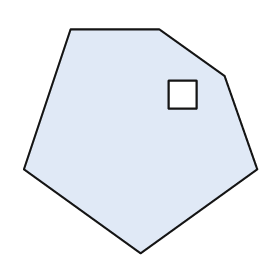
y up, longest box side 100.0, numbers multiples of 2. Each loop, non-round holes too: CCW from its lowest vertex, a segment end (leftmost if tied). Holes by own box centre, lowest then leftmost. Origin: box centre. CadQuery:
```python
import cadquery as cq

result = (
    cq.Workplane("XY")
    .moveTo(0.0, -48.0)
    .lineTo(50.0, -12.0)
    .lineTo(36.0, 28.0)
    .lineTo(8.0, 48.0)
    .lineTo(-30.0, 48.0)
    .lineTo(-50.0, -12.0)
    .close()
    .moveTo(12.0, 14.0)
    .lineTo(24.0, 14.0)
    .lineTo(24.0, 26.0)
    .lineTo(12.0, 26.0)
    .close()
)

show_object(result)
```